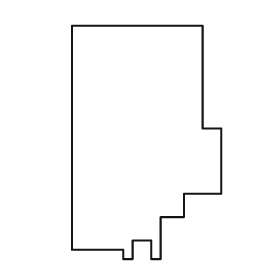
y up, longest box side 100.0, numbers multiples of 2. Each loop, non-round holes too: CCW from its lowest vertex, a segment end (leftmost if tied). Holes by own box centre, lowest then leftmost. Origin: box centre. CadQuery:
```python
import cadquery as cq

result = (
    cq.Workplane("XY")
    .moveTo(-10.0, -50.0)
    .lineTo(-6.0, -50.0)
    .lineTo(-6.0, -42.0)
    .lineTo(2.0, -42.0)
    .lineTo(2.0, -50.0)
    .lineTo(6.0, -50.0)
    .lineTo(6.0, -32.0)
    .lineTo(16.0, -32.0)
    .lineTo(16.0, -22.0)
    .lineTo(32.0, -22.0)
    .lineTo(32.0, 6.0)
    .lineTo(24.0, 6.0)
    .lineTo(24.0, 50.0)
    .lineTo(-32.0, 50.0)
    .lineTo(-32.0, -46.0)
    .lineTo(-10.0, -46.0)
    .close()
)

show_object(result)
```